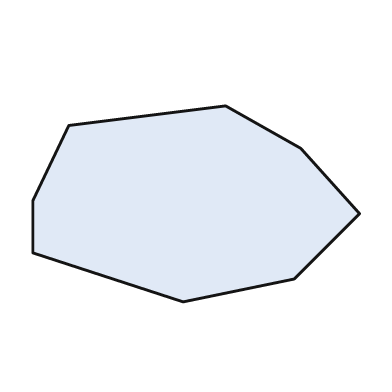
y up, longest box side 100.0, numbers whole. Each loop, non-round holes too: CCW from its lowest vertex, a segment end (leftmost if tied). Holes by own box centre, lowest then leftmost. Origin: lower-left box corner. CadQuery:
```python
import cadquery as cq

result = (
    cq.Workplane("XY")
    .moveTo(46.0, 0.0)
    .lineTo(80.0, 7.0)
    .lineTo(100.0, 27.0)
    .lineTo(82.0, 47.0)
    .lineTo(59.0, 60.0)
    .lineTo(11.0, 54.0)
    .lineTo(0.0, 31.0)
    .lineTo(0.0, 15.0)
    .close()
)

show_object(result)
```